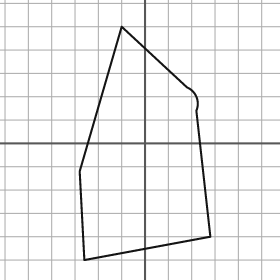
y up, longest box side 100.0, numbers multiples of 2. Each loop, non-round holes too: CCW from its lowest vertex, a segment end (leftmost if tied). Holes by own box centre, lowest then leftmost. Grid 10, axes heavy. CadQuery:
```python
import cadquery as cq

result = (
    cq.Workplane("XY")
    .moveTo(-26.0, -50.0)
    .lineTo(28.0, -40.0)
    .lineTo(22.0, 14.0)
    .threePointArc((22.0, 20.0), (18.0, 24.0))
    .lineTo(-10.0, 50.0)
    .lineTo(-28.0, -12.0)
    .close()
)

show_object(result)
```